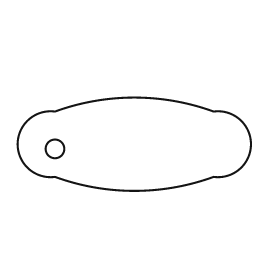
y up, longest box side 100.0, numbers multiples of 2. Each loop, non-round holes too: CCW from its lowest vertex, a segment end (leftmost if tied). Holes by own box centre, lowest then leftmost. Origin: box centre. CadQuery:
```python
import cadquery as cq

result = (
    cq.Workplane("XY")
    .moveTo(-34.0, -14.0)
    .threePointArc((0.0, -20.0), (34.0, -14.0))
    .threePointArc((50.0, 0.0), (34.0, 14.0))
    .threePointArc((0.0, 20.0), (-34.0, 14.0))
    .threePointArc((-50.0, 0.0), (-34.0, -14.0))
    .close()
    .moveTo(-34.0, -2.0)
    .circle(4.0)
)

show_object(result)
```